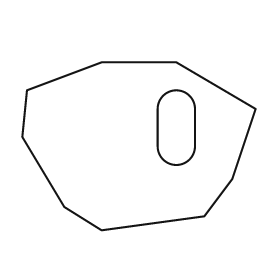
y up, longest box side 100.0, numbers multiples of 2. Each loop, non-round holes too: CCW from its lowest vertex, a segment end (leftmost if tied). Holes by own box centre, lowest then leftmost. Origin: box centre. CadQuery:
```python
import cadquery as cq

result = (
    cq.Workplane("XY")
    .moveTo(-16.0, -36.0)
    .lineTo(28.0, -30.0)
    .lineTo(40.0, -14.0)
    .lineTo(50.0, 16.0)
    .lineTo(16.0, 36.0)
    .lineTo(-16.0, 36.0)
    .lineTo(-48.0, 24.0)
    .lineTo(-50.0, 4.0)
    .lineTo(-32.0, -26.0)
    .close()
    .moveTo(8.0, 0.0)
    .threePointArc((16.0, -8.0), (24.0, 0.0))
    .lineTo(24.0, 16.0)
    .threePointArc((16.0, 24.0), (8.0, 16.0))
    .close()
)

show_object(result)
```